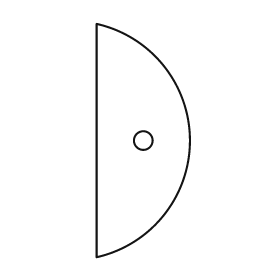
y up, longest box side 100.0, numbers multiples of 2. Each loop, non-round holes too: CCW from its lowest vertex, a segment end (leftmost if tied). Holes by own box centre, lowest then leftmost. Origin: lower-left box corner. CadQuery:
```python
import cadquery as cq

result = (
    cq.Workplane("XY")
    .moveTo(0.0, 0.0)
    .threePointArc((40.0, 50.0), (0.0, 100.0))
    .close()
    .moveTo(20.0, 50.0)
    .circle(4.0)
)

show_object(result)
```